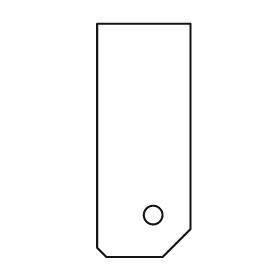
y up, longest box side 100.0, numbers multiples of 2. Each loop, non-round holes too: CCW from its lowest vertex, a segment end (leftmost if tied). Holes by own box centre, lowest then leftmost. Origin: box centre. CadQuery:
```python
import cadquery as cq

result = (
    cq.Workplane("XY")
    .moveTo(-16.0, -50.0)
    .lineTo(8.0, -50.0)
    .lineTo(20.0, -38.0)
    .lineTo(20.0, 50.0)
    .lineTo(-20.0, 50.0)
    .lineTo(-20.0, -46.0)
    .close()
    .moveTo(4.0, -32.0)
    .circle(4.0)
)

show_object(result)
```